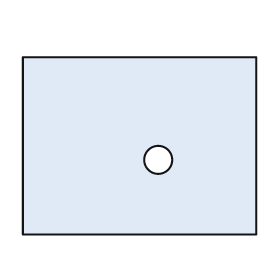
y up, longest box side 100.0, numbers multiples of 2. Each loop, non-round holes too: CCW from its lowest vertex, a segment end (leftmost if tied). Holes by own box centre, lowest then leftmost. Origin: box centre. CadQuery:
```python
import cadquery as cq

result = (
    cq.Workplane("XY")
    .moveTo(-50.0, -38.0)
    .lineTo(50.0, -38.0)
    .lineTo(50.0, 38.0)
    .lineTo(-50.0, 38.0)
    .close()
    .moveTo(8.0, -6.0)
    .circle(6.0)
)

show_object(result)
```